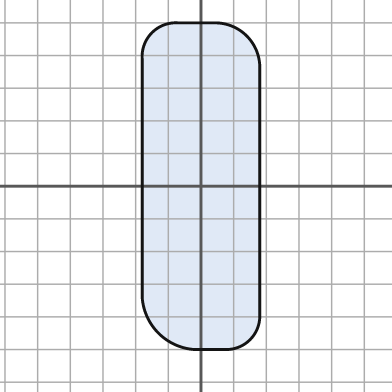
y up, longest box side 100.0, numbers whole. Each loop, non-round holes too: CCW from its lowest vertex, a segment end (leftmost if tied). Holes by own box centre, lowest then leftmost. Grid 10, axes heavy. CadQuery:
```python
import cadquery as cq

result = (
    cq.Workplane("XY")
    .moveTo(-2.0, -50.0)
    .lineTo(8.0, -50.0)
    .threePointArc((15.0, -47.0), (18.0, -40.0))
    .lineTo(18.0, 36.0)
    .threePointArc((14.0, 46.0), (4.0, 50.0))
    .lineTo(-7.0, 50.0)
    .threePointArc((-15.0, 47.0), (-18.0, 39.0))
    .lineTo(-18.0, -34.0)
    .threePointArc((-13.0, -45.0), (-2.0, -50.0))
    .close()
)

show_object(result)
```